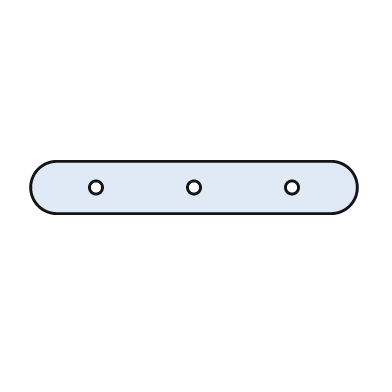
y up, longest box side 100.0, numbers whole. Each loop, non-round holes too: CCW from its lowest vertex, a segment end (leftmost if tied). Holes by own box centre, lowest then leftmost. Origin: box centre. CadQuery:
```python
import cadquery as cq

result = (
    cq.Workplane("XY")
    .moveTo(-42.0, -8.0)
    .lineTo(42.0, -8.0)
    .threePointArc((50.0, 0.0), (42.0, 8.0))
    .lineTo(-42.0, 8.0)
    .threePointArc((-50.0, 0.0), (-42.0, -8.0))
    .close()
    .moveTo(-30.0, 0.0)
    .circle(2.0)
    .moveTo(0.0, 0.0)
    .circle(2.0)
    .moveTo(30.0, 0.0)
    .circle(2.0)
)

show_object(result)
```